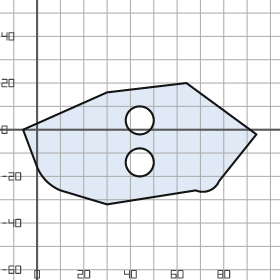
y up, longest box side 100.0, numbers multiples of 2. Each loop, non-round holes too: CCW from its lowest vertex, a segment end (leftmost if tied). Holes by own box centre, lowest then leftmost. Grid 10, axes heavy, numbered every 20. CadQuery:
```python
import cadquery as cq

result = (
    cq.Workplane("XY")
    .moveTo(30.0, -32.0)
    .lineTo(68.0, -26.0)
    .threePointArc((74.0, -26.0), (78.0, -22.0))
    .lineTo(94.0, -2.0)
    .lineTo(64.0, 20.0)
    .lineTo(30.0, 16.0)
    .lineTo(-6.0, 0.0)
    .lineTo(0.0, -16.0)
    .threePointArc((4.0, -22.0), (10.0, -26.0))
    .close()
    .moveTo(44.0, -14.0)
    .circle(6.0)
    .moveTo(44.0, 4.0)
    .circle(6.0)
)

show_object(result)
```